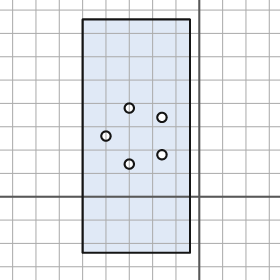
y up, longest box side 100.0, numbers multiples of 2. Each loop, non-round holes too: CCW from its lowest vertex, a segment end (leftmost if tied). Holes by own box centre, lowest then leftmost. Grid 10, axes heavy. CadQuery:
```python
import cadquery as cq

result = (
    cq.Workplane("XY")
    .moveTo(-50.0, -24.0)
    .lineTo(-4.0, -24.0)
    .lineTo(-4.0, 76.0)
    .lineTo(-50.0, 76.0)
    .close()
    .moveTo(-30.0, 14.0)
    .circle(2.0)
    .moveTo(-16.0, 18.0)
    .circle(2.0)
    .moveTo(-40.0, 26.0)
    .circle(2.0)
    .moveTo(-16.0, 34.0)
    .circle(2.0)
    .moveTo(-30.0, 38.0)
    .circle(2.0)
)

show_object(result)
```